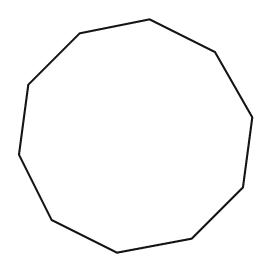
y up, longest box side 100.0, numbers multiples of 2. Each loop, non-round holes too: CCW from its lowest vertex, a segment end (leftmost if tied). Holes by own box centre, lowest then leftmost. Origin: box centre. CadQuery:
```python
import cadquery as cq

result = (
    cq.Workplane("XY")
    .moveTo(-8.0, -50.0)
    .lineTo(24.0, -44.0)
    .lineTo(46.0, -22.0)
    .lineTo(50.0, 8.0)
    .lineTo(34.0, 36.0)
    .lineTo(6.0, 50.0)
    .lineTo(-24.0, 44.0)
    .lineTo(-46.0, 22.0)
    .lineTo(-50.0, -8.0)
    .lineTo(-36.0, -36.0)
    .close()
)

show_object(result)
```